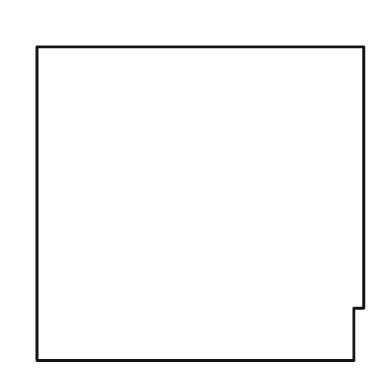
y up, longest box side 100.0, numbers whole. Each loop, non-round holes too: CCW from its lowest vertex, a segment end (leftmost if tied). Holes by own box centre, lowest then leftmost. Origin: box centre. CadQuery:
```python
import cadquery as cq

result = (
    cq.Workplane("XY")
    .moveTo(-50.0, -48.0)
    .lineTo(47.0, -48.0)
    .lineTo(47.0, -32.0)
    .lineTo(50.0, -32.0)
    .lineTo(50.0, 48.0)
    .lineTo(-50.0, 48.0)
    .close()
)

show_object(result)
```